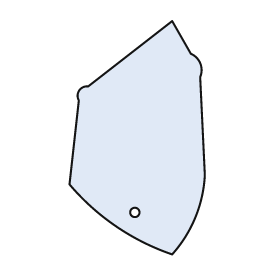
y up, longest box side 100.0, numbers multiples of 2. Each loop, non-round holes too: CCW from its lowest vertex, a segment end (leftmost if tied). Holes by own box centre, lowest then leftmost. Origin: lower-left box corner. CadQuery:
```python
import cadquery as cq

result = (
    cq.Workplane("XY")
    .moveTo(44.0, 0.0)
    .threePointArc((54.0, 16.0), (58.0, 34.0))
    .lineTo(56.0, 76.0)
    .threePointArc((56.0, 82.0), (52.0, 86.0))
    .lineTo(44.0, 100.0)
    .lineTo(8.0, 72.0)
    .threePointArc((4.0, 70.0), (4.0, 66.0))
    .lineTo(0.0, 30.0)
    .threePointArc((20.0, 12.0), (44.0, 0.0))
    .close()
    .moveTo(28.0, 18.0)
    .circle(2.0)
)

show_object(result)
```